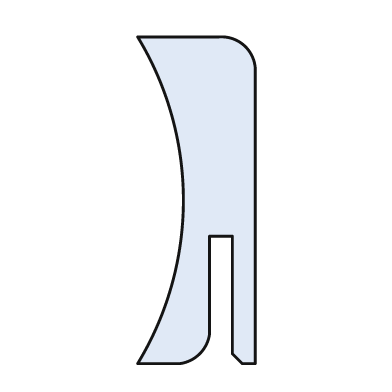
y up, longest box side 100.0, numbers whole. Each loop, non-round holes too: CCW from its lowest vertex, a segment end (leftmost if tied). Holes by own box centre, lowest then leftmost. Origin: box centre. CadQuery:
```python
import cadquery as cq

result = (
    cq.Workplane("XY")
    .moveTo(-18.0, -50.0)
    .lineTo(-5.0, -50.0)
    .threePointArc((1.0, -47.0), (4.0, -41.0))
    .lineTo(4.0, -11.0)
    .lineTo(11.0, -11.0)
    .lineTo(11.0, -47.0)
    .lineTo(14.0, -50.0)
    .lineTo(18.0, -50.0)
    .lineTo(18.0, 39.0)
    .threePointArc((15.0, 47.0), (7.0, 50.0))
    .lineTo(-18.0, 50.0)
    .threePointArc((-4.0, 0.0), (-18.0, -50.0))
    .close()
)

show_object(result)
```